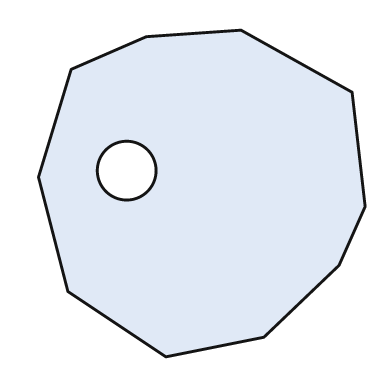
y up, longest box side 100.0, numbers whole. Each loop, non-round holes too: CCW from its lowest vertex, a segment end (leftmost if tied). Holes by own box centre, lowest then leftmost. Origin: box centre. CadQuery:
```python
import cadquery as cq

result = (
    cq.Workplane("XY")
    .moveTo(-11.0, -50.0)
    .lineTo(19.0, -44.0)
    .lineTo(42.0, -22.0)
    .lineTo(50.0, -4.0)
    .lineTo(46.0, 31.0)
    .lineTo(12.0, 50.0)
    .lineTo(-17.0, 48.0)
    .lineTo(-40.0, 38.0)
    .lineTo(-50.0, 5.0)
    .lineTo(-41.0, -30.0)
    .close()
    .moveTo(-23.0, 7.0)
    .circle(9.0)
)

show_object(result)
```